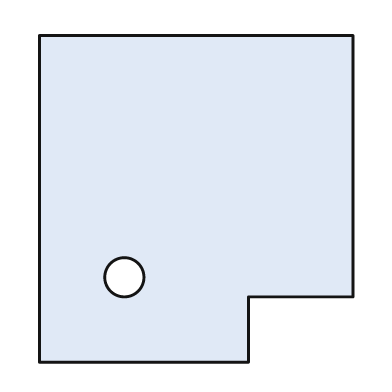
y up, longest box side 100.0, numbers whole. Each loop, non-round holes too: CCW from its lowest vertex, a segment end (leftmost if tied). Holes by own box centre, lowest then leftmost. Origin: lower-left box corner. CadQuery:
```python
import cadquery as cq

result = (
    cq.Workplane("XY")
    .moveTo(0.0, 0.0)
    .lineTo(64.0, 0.0)
    .lineTo(64.0, 20.0)
    .lineTo(96.0, 20.0)
    .lineTo(96.0, 100.0)
    .lineTo(0.0, 100.0)
    .close()
    .moveTo(26.0, 26.0)
    .circle(6.0)
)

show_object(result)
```